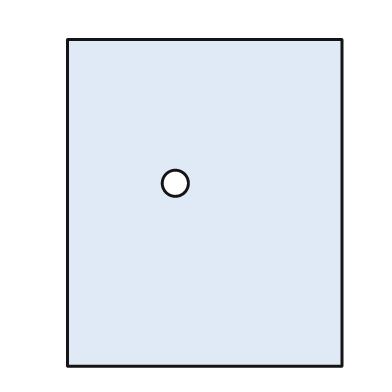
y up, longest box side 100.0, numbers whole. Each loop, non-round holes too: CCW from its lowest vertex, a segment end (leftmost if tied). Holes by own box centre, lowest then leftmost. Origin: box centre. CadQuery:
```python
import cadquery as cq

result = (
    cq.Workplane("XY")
    .moveTo(-42.0, -50.0)
    .lineTo(42.0, -50.0)
    .lineTo(42.0, 50.0)
    .lineTo(-42.0, 50.0)
    .close()
    .moveTo(-9.0, 6.0)
    .circle(4.0)
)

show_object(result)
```